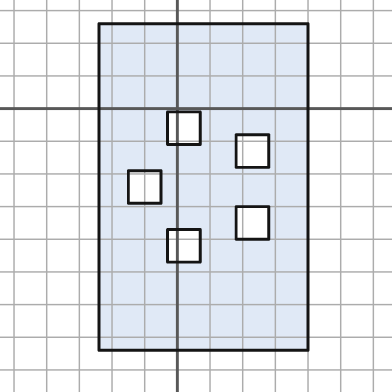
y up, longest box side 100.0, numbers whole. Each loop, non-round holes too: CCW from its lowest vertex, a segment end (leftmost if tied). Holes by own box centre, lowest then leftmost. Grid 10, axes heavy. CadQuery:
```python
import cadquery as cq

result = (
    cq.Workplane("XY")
    .moveTo(-24.0, -74.0)
    .lineTo(40.0, -74.0)
    .lineTo(40.0, 26.0)
    .lineTo(-24.0, 26.0)
    .close()
    .moveTo(-3.0, -47.0)
    .lineTo(7.0, -47.0)
    .lineTo(7.0, -37.0)
    .lineTo(-3.0, -37.0)
    .close()
    .moveTo(18.0, -40.0)
    .lineTo(28.0, -40.0)
    .lineTo(28.0, -30.0)
    .lineTo(18.0, -30.0)
    .close()
    .moveTo(-15.0, -29.0)
    .lineTo(-5.0, -29.0)
    .lineTo(-5.0, -19.0)
    .lineTo(-15.0, -19.0)
    .close()
    .moveTo(18.0, -18.0)
    .lineTo(28.0, -18.0)
    .lineTo(28.0, -8.0)
    .lineTo(18.0, -8.0)
    .close()
    .moveTo(-3.0, -11.0)
    .lineTo(7.0, -11.0)
    .lineTo(7.0, -1.0)
    .lineTo(-3.0, -1.0)
    .close()
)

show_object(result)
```